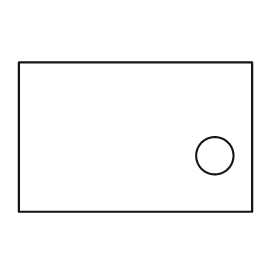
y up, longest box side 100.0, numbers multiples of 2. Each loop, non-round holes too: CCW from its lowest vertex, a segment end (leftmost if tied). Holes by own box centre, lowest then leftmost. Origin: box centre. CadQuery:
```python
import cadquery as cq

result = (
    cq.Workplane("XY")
    .moveTo(-50.0, -32.0)
    .lineTo(50.0, -32.0)
    .lineTo(50.0, 32.0)
    .lineTo(-50.0, 32.0)
    .close()
    .moveTo(34.0, -8.0)
    .circle(8.0)
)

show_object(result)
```